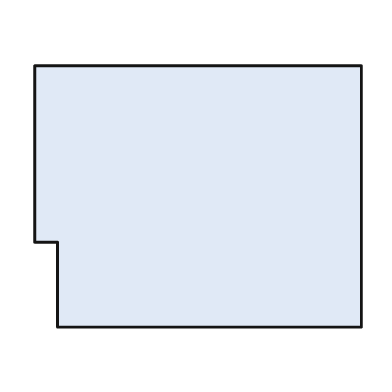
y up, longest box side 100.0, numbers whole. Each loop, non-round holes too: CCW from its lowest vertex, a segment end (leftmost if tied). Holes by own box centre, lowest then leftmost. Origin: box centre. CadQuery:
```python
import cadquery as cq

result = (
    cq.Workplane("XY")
    .moveTo(-43.0, -40.0)
    .lineTo(50.0, -40.0)
    .lineTo(50.0, 40.0)
    .lineTo(-50.0, 40.0)
    .lineTo(-50.0, -14.0)
    .lineTo(-43.0, -14.0)
    .close()
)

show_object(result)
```